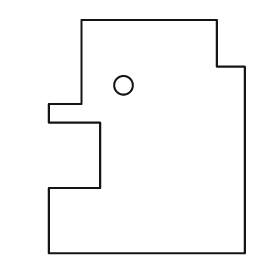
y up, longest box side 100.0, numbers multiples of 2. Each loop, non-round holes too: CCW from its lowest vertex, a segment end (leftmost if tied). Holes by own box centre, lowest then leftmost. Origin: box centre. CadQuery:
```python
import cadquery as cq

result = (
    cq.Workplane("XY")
    .moveTo(-42.0, -50.0)
    .lineTo(42.0, -50.0)
    .lineTo(42.0, 30.0)
    .lineTo(30.0, 30.0)
    .lineTo(30.0, 50.0)
    .lineTo(-28.0, 50.0)
    .lineTo(-28.0, 14.0)
    .lineTo(-42.0, 14.0)
    .lineTo(-42.0, 6.0)
    .lineTo(-20.0, 6.0)
    .lineTo(-20.0, -22.0)
    .lineTo(-42.0, -22.0)
    .close()
    .moveTo(-10.0, 22.0)
    .circle(4.0)
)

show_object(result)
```